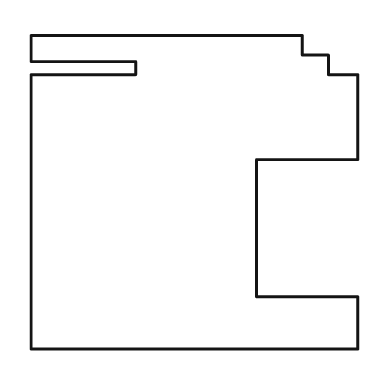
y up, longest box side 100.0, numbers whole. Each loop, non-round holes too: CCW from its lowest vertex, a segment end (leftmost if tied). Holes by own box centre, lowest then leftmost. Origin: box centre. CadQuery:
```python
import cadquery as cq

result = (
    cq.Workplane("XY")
    .moveTo(-50.0, -48.0)
    .lineTo(50.0, -48.0)
    .lineTo(50.0, -32.0)
    .lineTo(19.0, -32.0)
    .lineTo(19.0, 10.0)
    .lineTo(50.0, 10.0)
    .lineTo(50.0, 36.0)
    .lineTo(41.0, 36.0)
    .lineTo(41.0, 42.0)
    .lineTo(33.0, 42.0)
    .lineTo(33.0, 48.0)
    .lineTo(-50.0, 48.0)
    .lineTo(-50.0, 40.0)
    .lineTo(-18.0, 40.0)
    .lineTo(-18.0, 36.0)
    .lineTo(-50.0, 36.0)
    .close()
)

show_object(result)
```